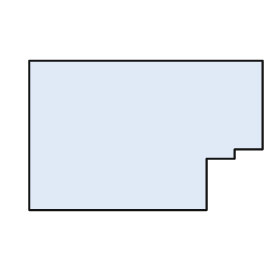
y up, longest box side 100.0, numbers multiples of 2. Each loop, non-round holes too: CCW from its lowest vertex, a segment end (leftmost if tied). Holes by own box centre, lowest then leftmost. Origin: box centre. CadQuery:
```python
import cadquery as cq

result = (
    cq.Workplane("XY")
    .moveTo(-50.0, -32.0)
    .lineTo(26.0, -32.0)
    .lineTo(26.0, -10.0)
    .lineTo(38.0, -10.0)
    .lineTo(38.0, -6.0)
    .lineTo(50.0, -6.0)
    .lineTo(50.0, 32.0)
    .lineTo(-50.0, 32.0)
    .close()
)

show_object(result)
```